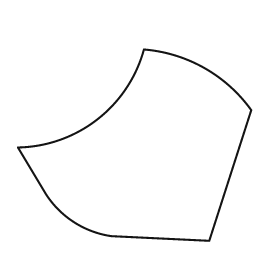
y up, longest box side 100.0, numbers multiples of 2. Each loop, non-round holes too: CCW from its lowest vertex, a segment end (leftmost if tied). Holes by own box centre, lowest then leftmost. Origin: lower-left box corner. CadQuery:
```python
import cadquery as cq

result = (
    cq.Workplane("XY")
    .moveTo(82.0, 0.0)
    .lineTo(100.0, 56.0)
    .threePointArc((80.0, 74.0), (54.0, 82.0))
    .threePointArc((34.0, 52.0), (0.0, 40.0))
    .lineTo(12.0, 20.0)
    .threePointArc((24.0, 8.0), (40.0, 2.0))
    .close()
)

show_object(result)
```